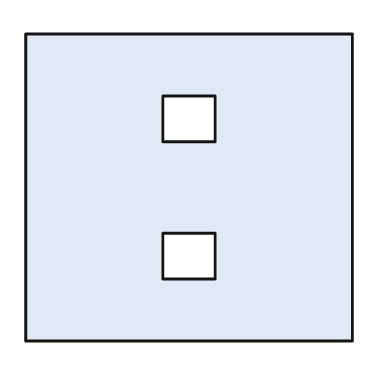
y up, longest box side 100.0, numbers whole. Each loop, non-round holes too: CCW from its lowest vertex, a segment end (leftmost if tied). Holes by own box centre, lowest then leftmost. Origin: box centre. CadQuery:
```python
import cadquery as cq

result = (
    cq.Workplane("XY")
    .moveTo(-50.0, -47.0)
    .lineTo(50.0, -47.0)
    .lineTo(50.0, 47.0)
    .lineTo(-50.0, 47.0)
    .close()
    .moveTo(-8.0, -28.0)
    .lineTo(8.0, -28.0)
    .lineTo(8.0, -14.0)
    .lineTo(-8.0, -14.0)
    .close()
    .moveTo(-8.0, 14.0)
    .lineTo(8.0, 14.0)
    .lineTo(8.0, 28.0)
    .lineTo(-8.0, 28.0)
    .close()
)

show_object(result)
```